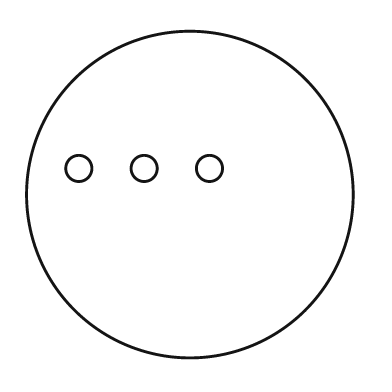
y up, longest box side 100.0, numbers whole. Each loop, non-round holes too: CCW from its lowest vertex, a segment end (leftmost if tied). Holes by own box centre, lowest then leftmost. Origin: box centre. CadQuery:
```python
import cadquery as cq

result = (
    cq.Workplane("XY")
    .moveTo(0.0, 0.0)
    .circle(50.0)
    .moveTo(-34.0, 8.0)
    .circle(4.0)
    .moveTo(-14.0, 8.0)
    .circle(4.0)
    .moveTo(6.0, 8.0)
    .circle(4.0)
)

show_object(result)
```